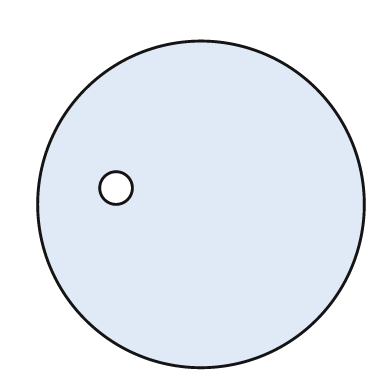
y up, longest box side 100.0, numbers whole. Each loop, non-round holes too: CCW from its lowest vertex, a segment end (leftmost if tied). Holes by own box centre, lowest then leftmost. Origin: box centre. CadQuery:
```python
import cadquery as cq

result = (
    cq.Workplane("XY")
    .moveTo(0.0, 0.0)
    .circle(50.0)
    .moveTo(-26.0, 5.0)
    .circle(5.0)
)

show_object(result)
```